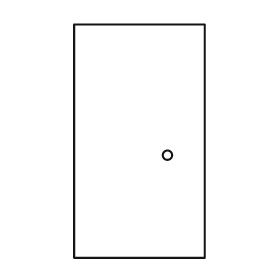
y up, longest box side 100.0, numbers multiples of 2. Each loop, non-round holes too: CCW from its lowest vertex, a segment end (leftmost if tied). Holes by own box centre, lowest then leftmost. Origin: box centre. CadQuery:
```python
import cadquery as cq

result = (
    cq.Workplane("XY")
    .moveTo(-28.0, -50.0)
    .lineTo(28.0, -50.0)
    .lineTo(28.0, 50.0)
    .lineTo(-28.0, 50.0)
    .close()
    .moveTo(12.0, -6.0)
    .circle(2.0)
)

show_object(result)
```